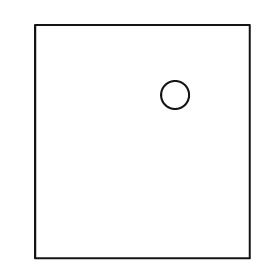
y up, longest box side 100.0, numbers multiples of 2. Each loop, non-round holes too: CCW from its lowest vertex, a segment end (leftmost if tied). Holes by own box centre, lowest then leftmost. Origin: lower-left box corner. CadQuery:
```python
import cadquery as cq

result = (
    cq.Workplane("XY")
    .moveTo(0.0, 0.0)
    .lineTo(92.0, 0.0)
    .lineTo(92.0, 100.0)
    .lineTo(0.0, 100.0)
    .close()
    .moveTo(60.0, 70.0)
    .circle(6.0)
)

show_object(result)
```